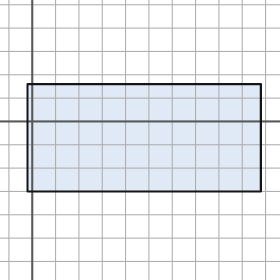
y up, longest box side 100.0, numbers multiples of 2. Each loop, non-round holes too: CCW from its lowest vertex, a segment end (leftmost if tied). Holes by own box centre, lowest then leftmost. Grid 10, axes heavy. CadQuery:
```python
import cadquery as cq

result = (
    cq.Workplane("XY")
    .moveTo(-2.0, -30.0)
    .lineTo(98.0, -30.0)
    .lineTo(98.0, 16.0)
    .lineTo(-2.0, 16.0)
    .close()
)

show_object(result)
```